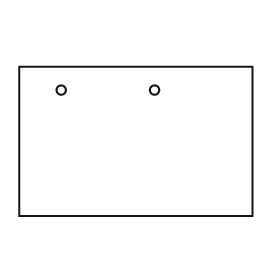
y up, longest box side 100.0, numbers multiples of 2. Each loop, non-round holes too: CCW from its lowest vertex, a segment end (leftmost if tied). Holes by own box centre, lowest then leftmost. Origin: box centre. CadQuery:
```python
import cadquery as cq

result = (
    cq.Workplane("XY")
    .moveTo(-50.0, -32.0)
    .lineTo(50.0, -32.0)
    .lineTo(50.0, 32.0)
    .lineTo(-50.0, 32.0)
    .close()
    .moveTo(-32.0, 22.0)
    .circle(2.0)
    .moveTo(8.0, 22.0)
    .circle(2.0)
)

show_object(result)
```